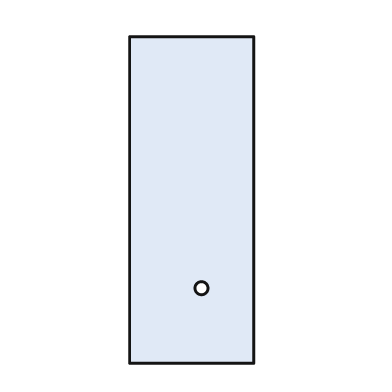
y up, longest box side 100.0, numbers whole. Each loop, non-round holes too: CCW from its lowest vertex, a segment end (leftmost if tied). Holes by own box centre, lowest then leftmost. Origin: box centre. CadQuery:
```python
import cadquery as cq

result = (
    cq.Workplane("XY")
    .moveTo(-19.0, -50.0)
    .lineTo(19.0, -50.0)
    .lineTo(19.0, 50.0)
    .lineTo(-19.0, 50.0)
    .close()
    .moveTo(3.0, -27.0)
    .circle(2.0)
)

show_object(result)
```